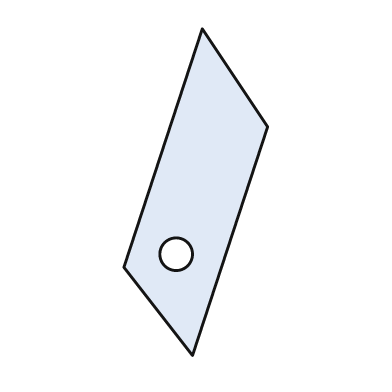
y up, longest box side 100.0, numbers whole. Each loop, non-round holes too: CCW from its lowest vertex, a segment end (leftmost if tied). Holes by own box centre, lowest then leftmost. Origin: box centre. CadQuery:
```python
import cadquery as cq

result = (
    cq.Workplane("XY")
    .moveTo(-1.0, -50.0)
    .lineTo(22.0, 20.0)
    .lineTo(2.0, 50.0)
    .lineTo(-22.0, -23.0)
    .close()
    .moveTo(-6.0, -19.0)
    .circle(5.0)
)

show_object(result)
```